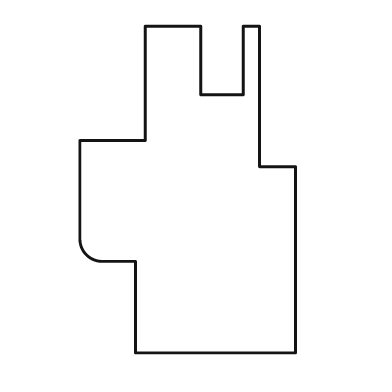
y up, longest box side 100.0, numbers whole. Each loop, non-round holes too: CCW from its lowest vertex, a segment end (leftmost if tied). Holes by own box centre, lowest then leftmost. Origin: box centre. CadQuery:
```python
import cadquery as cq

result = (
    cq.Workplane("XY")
    .moveTo(-16.0, -50.0)
    .lineTo(33.0, -50.0)
    .lineTo(33.0, 7.0)
    .lineTo(22.0, 7.0)
    .lineTo(22.0, 50.0)
    .lineTo(17.0, 50.0)
    .lineTo(17.0, 29.0)
    .lineTo(4.0, 29.0)
    .lineTo(4.0, 50.0)
    .lineTo(-13.0, 50.0)
    .lineTo(-13.0, 15.0)
    .lineTo(-33.0, 15.0)
    .lineTo(-33.0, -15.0)
    .threePointArc((-31.0, -20.0), (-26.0, -22.0))
    .lineTo(-16.0, -22.0)
    .close()
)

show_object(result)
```